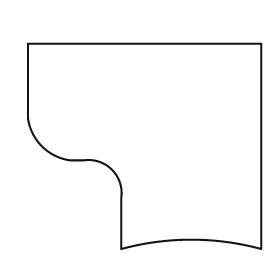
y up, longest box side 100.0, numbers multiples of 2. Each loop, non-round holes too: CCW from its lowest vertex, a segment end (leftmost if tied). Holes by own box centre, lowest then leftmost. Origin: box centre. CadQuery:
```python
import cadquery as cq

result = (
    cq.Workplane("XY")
    .moveTo(-10.0, -44.0)
    .threePointArc((20.0, -40.0), (50.0, -44.0))
    .lineTo(50.0, 44.0)
    .lineTo(-50.0, 44.0)
    .lineTo(-50.0, 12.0)
    .threePointArc((-44.0, 0.0), (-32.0, -6.0))
    .lineTo(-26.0, -6.0)
    .threePointArc((-14.0, -10.0), (-10.0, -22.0))
    .close()
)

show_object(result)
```